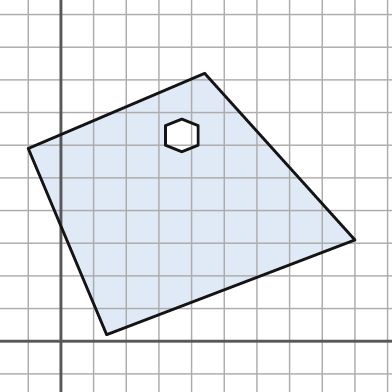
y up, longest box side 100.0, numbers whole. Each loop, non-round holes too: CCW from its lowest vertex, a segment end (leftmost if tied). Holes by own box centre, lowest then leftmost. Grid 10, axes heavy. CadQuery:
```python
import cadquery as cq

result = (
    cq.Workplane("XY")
    .moveTo(14.0, 2.0)
    .lineTo(90.0, 31.0)
    .lineTo(44.0, 82.0)
    .lineTo(-10.0, 59.0)
    .close()
    .moveTo(37.0, 58.0)
    .lineTo(42.0, 60.0)
    .lineTo(42.0, 66.0)
    .lineTo(37.0, 68.0)
    .lineTo(32.0, 66.0)
    .lineTo(32.0, 60.0)
    .close()
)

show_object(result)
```